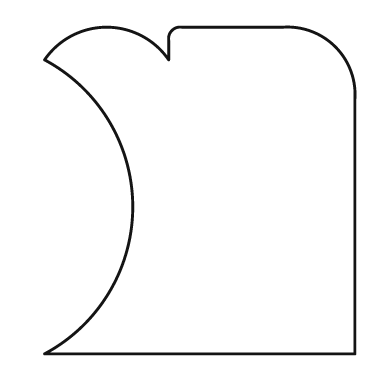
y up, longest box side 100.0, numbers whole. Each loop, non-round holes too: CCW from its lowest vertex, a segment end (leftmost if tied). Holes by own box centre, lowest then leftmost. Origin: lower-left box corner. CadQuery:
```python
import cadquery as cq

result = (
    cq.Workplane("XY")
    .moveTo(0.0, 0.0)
    .lineTo(95.0, 0.0)
    .lineTo(95.0, 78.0)
    .threePointArc((89.0, 94.0), (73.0, 100.0))
    .lineTo(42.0, 100.0)
    .threePointArc((39.0, 99.0), (38.0, 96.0))
    .lineTo(38.0, 90.0)
    .threePointArc((19.0, 100.0), (0.0, 90.0))
    .threePointArc((27.0, 45.0), (0.0, 0.0))
    .close()
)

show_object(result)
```